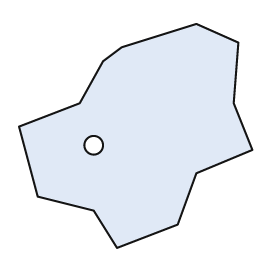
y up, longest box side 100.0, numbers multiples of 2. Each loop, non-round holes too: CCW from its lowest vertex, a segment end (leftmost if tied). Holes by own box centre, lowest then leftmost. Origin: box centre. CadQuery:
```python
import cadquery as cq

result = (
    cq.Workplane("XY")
    .moveTo(-8.0, -48.0)
    .lineTo(18.0, -38.0)
    .lineTo(26.0, -16.0)
    .lineTo(50.0, -6.0)
    .lineTo(42.0, 14.0)
    .lineTo(44.0, 40.0)
    .lineTo(26.0, 48.0)
    .lineTo(-6.0, 38.0)
    .lineTo(-14.0, 32.0)
    .lineTo(-24.0, 14.0)
    .lineTo(-50.0, 4.0)
    .lineTo(-42.0, -26.0)
    .lineTo(-18.0, -32.0)
    .close()
    .moveTo(-18.0, -4.0)
    .circle(4.0)
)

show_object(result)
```